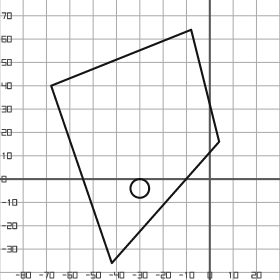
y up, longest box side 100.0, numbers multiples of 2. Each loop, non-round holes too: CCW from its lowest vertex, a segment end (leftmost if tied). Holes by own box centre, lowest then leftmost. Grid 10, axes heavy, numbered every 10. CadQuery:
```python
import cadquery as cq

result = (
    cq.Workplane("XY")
    .moveTo(-42.0, -36.0)
    .lineTo(4.0, 16.0)
    .lineTo(-8.0, 64.0)
    .lineTo(-68.0, 40.0)
    .close()
    .moveTo(-30.0, -4.0)
    .circle(4.0)
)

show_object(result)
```